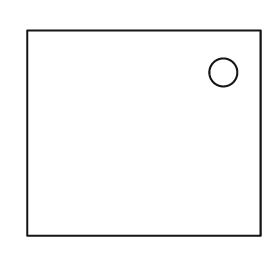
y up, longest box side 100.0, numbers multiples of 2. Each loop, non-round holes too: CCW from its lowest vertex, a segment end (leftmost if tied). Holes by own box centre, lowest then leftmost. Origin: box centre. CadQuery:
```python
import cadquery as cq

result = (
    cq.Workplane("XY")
    .moveTo(-50.0, -44.0)
    .lineTo(50.0, -44.0)
    .lineTo(50.0, 44.0)
    .lineTo(-50.0, 44.0)
    .close()
    .moveTo(34.0, 26.0)
    .circle(6.0)
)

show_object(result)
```